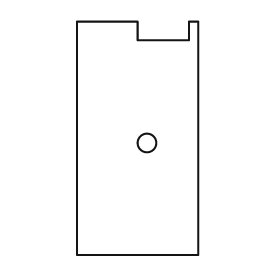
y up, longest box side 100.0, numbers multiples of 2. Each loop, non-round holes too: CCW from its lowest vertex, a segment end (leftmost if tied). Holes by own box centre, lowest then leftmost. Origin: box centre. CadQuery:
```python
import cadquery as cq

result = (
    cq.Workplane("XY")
    .moveTo(-26.0, -50.0)
    .lineTo(26.0, -50.0)
    .lineTo(26.0, 50.0)
    .lineTo(22.0, 50.0)
    .lineTo(22.0, 42.0)
    .lineTo(0.0, 42.0)
    .lineTo(0.0, 50.0)
    .lineTo(-26.0, 50.0)
    .close()
    .moveTo(4.0, -2.0)
    .circle(4.0)
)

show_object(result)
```